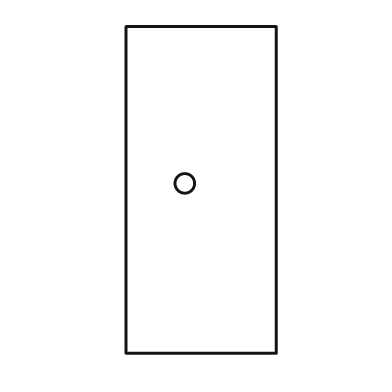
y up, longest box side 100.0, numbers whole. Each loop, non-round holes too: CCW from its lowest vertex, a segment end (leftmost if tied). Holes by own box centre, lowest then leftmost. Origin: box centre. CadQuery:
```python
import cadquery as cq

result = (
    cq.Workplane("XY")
    .moveTo(-23.0, -50.0)
    .lineTo(23.0, -50.0)
    .lineTo(23.0, 50.0)
    .lineTo(-23.0, 50.0)
    .close()
    .moveTo(-5.0, 2.0)
    .circle(3.0)
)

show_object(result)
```